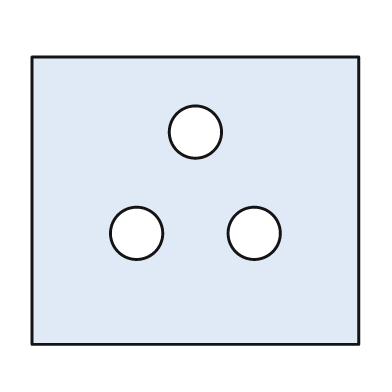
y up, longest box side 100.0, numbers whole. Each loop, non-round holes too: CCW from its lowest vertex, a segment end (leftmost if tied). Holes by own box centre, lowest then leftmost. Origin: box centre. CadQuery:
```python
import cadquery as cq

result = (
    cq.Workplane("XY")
    .moveTo(-50.0, -44.0)
    .lineTo(50.0, -44.0)
    .lineTo(50.0, 44.0)
    .lineTo(-50.0, 44.0)
    .close()
    .moveTo(-18.0, -10.0)
    .circle(8.0)
    .moveTo(18.0, -10.0)
    .circle(8.0)
    .moveTo(0.0, 21.0)
    .circle(8.0)
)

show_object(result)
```